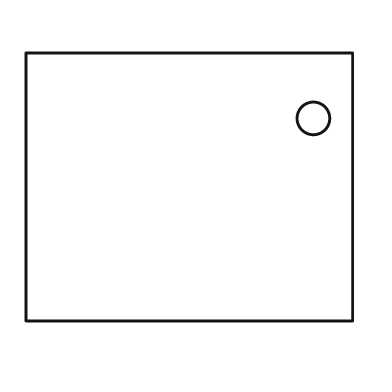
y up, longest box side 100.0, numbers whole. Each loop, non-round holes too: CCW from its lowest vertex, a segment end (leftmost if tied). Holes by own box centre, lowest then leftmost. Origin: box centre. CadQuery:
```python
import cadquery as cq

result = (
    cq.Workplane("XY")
    .moveTo(-50.0, -41.0)
    .lineTo(50.0, -41.0)
    .lineTo(50.0, 41.0)
    .lineTo(-50.0, 41.0)
    .close()
    .moveTo(38.0, 21.0)
    .circle(5.0)
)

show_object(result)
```